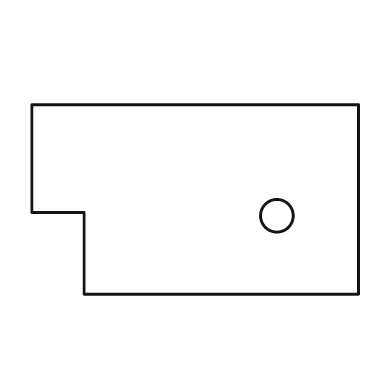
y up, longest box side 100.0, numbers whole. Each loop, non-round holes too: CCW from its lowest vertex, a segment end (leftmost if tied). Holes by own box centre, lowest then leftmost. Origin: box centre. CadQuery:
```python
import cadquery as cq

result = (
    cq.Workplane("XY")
    .moveTo(-34.0, -29.0)
    .lineTo(50.0, -29.0)
    .lineTo(50.0, 29.0)
    .lineTo(-50.0, 29.0)
    .lineTo(-50.0, -4.0)
    .lineTo(-34.0, -4.0)
    .close()
    .moveTo(25.0, -5.0)
    .circle(5.0)
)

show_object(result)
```